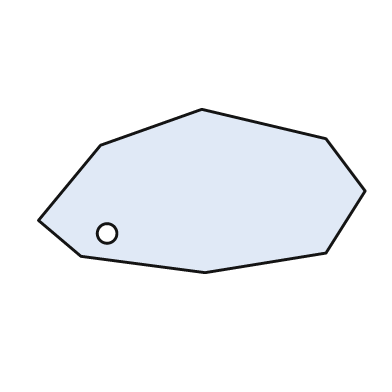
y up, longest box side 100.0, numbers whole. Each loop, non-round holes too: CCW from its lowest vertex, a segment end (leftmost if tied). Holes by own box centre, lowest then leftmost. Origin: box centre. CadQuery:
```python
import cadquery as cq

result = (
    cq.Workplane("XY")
    .moveTo(1.0, -25.0)
    .lineTo(38.0, -19.0)
    .lineTo(50.0, 0.0)
    .lineTo(38.0, 16.0)
    .lineTo(0.0, 25.0)
    .lineTo(-31.0, 14.0)
    .lineTo(-50.0, -9.0)
    .lineTo(-37.0, -20.0)
    .close()
    .moveTo(-29.0, -13.0)
    .circle(3.0)
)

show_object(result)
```